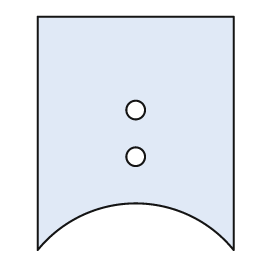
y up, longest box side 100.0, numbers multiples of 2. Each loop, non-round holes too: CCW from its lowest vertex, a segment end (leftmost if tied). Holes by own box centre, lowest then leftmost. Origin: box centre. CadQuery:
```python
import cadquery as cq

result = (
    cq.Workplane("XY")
    .moveTo(-42.0, -50.0)
    .threePointArc((0.0, -30.0), (42.0, -50.0))
    .lineTo(42.0, 50.0)
    .lineTo(-42.0, 50.0)
    .close()
    .moveTo(0.0, -10.0)
    .circle(4.0)
    .moveTo(0.0, 10.0)
    .circle(4.0)
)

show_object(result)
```